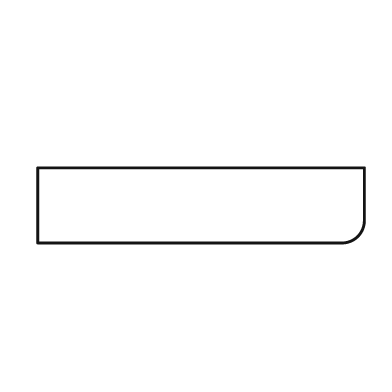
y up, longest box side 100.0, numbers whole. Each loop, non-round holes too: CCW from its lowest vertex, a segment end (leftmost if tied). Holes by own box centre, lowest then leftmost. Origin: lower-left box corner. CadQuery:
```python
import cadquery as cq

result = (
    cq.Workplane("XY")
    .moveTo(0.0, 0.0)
    .lineTo(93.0, 0.0)
    .threePointArc((98.0, 2.0), (100.0, 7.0))
    .lineTo(100.0, 23.0)
    .lineTo(0.0, 23.0)
    .close()
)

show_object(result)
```